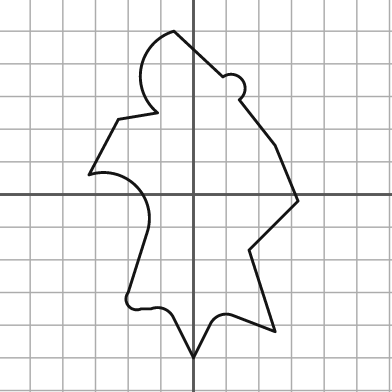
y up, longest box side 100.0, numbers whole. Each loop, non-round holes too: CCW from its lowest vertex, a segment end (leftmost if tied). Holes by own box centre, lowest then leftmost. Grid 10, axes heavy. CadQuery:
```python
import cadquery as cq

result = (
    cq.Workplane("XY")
    .moveTo(0.0, -50.0)
    .lineTo(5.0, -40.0)
    .threePointArc((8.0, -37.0), (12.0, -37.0))
    .lineTo(25.0, -42.0)
    .lineTo(17.0, -17.0)
    .lineTo(32.0, -2.0)
    .lineTo(25.0, 15.0)
    .lineTo(14.0, 29.0)
    .threePointArc((15.0, 35.0), (9.0, 36.0))
    .lineTo(-6.0, 50.0)
    .threePointArc((-16.0, 39.0), (-11.0, 25.0))
    .lineTo(-23.0, 23.0)
    .lineTo(-32.0, 6.0)
    .threePointArc((-18.0, 3.0), (-14.0, -11.0))
    .lineTo(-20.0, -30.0)
    .threePointArc((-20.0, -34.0), (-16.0, -35.0))
    .lineTo(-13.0, -35.0)
    .threePointArc((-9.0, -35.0), (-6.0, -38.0))
    .close()
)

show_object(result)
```